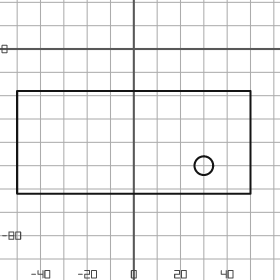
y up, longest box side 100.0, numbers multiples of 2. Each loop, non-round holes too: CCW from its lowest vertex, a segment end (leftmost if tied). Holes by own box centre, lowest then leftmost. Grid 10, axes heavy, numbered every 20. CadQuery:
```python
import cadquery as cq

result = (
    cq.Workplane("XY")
    .moveTo(-50.0, -62.0)
    .lineTo(50.0, -62.0)
    .lineTo(50.0, -18.0)
    .lineTo(-50.0, -18.0)
    .close()
    .moveTo(30.0, -50.0)
    .circle(4.0)
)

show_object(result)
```